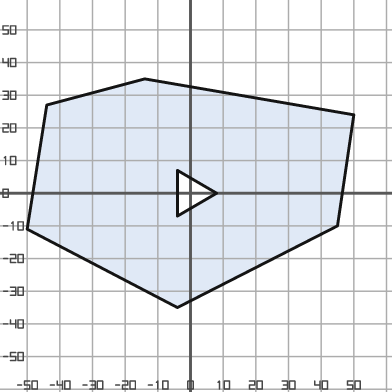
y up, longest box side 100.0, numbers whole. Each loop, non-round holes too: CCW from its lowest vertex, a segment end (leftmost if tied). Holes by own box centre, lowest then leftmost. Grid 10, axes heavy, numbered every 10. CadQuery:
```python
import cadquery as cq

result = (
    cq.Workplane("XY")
    .moveTo(-4.0, -35.0)
    .lineTo(45.0, -10.0)
    .lineTo(50.0, 24.0)
    .lineTo(-14.0, 35.0)
    .lineTo(-44.0, 27.0)
    .lineTo(-50.0, -11.0)
    .close()
    .moveTo(-4.0, -7.0)
    .lineTo(8.0, 0.0)
    .lineTo(-4.0, 7.0)
    .close()
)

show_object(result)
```